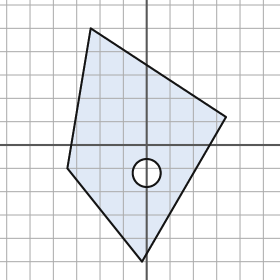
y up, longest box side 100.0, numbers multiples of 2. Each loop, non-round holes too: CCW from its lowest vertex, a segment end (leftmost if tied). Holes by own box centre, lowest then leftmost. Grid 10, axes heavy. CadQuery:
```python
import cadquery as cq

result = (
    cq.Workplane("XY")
    .moveTo(-2.0, -50.0)
    .lineTo(34.0, 12.0)
    .lineTo(-24.0, 50.0)
    .lineTo(-34.0, -10.0)
    .close()
    .moveTo(0.0, -12.0)
    .circle(6.0)
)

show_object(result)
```